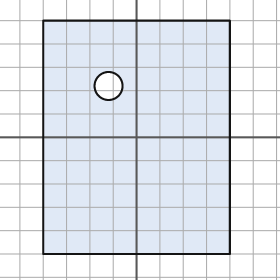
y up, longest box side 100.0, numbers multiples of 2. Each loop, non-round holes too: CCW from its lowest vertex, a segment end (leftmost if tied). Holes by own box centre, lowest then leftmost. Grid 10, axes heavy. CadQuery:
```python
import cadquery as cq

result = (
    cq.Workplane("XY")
    .moveTo(-40.0, -50.0)
    .lineTo(40.0, -50.0)
    .lineTo(40.0, 50.0)
    .lineTo(-40.0, 50.0)
    .close()
    .moveTo(-12.0, 22.0)
    .circle(6.0)
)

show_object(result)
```